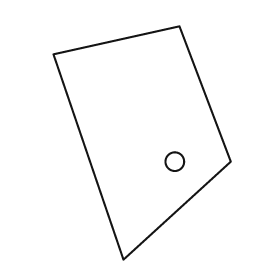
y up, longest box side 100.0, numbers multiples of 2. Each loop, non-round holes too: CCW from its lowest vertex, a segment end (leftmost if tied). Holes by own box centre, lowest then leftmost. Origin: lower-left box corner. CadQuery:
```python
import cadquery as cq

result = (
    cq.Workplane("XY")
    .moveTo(30.0, 0.0)
    .lineTo(76.0, 42.0)
    .lineTo(54.0, 100.0)
    .lineTo(0.0, 88.0)
    .close()
    .moveTo(52.0, 42.0)
    .circle(4.0)
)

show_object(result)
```